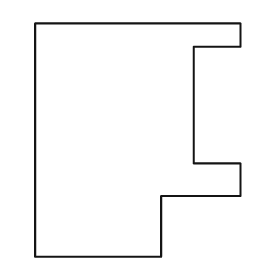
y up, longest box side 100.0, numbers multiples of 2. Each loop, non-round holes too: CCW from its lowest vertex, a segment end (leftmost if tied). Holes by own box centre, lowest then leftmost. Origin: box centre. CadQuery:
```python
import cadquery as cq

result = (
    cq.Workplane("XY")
    .moveTo(-44.0, -50.0)
    .lineTo(10.0, -50.0)
    .lineTo(10.0, -24.0)
    .lineTo(44.0, -24.0)
    .lineTo(44.0, -10.0)
    .lineTo(24.0, -10.0)
    .lineTo(24.0, 40.0)
    .lineTo(44.0, 40.0)
    .lineTo(44.0, 50.0)
    .lineTo(-44.0, 50.0)
    .close()
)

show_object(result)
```